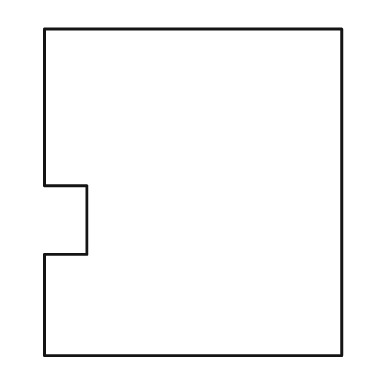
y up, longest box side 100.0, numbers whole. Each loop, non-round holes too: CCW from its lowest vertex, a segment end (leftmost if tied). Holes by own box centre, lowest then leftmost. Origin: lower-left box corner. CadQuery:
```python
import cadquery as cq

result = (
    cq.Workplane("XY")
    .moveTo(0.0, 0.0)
    .lineTo(91.0, 0.0)
    .lineTo(91.0, 100.0)
    .lineTo(0.0, 100.0)
    .lineTo(0.0, 52.0)
    .lineTo(13.0, 52.0)
    .lineTo(13.0, 31.0)
    .lineTo(0.0, 31.0)
    .close()
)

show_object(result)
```